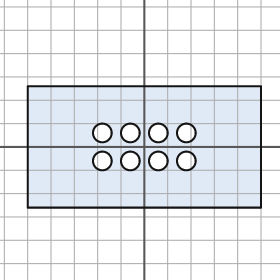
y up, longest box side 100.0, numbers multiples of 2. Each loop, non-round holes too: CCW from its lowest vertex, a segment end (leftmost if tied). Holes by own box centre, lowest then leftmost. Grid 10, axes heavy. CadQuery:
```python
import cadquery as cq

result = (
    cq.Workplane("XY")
    .moveTo(-50.0, -26.0)
    .lineTo(50.0, -26.0)
    .lineTo(50.0, 26.0)
    .lineTo(-50.0, 26.0)
    .close()
    .moveTo(-18.0, -6.0)
    .circle(4.0)
    .moveTo(-6.0, -6.0)
    .circle(4.0)
    .moveTo(6.0, -6.0)
    .circle(4.0)
    .moveTo(18.0, -6.0)
    .circle(4.0)
    .moveTo(-18.0, 6.0)
    .circle(4.0)
    .moveTo(-6.0, 6.0)
    .circle(4.0)
    .moveTo(6.0, 6.0)
    .circle(4.0)
    .moveTo(18.0, 6.0)
    .circle(4.0)
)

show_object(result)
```